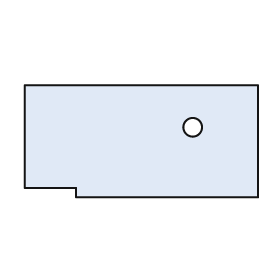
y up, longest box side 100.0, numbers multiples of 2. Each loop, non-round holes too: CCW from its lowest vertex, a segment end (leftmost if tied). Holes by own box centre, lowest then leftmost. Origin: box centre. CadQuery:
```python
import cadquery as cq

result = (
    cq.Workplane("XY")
    .moveTo(-28.0, -24.0)
    .lineTo(50.0, -24.0)
    .lineTo(50.0, 24.0)
    .lineTo(-50.0, 24.0)
    .lineTo(-50.0, -20.0)
    .lineTo(-28.0, -20.0)
    .close()
    .moveTo(22.0, 6.0)
    .circle(4.0)
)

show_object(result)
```